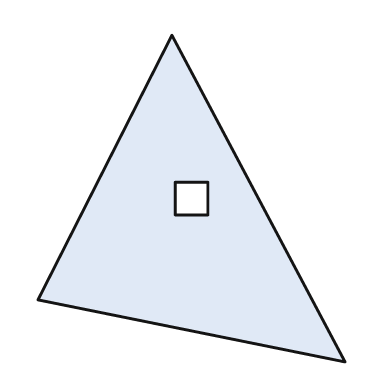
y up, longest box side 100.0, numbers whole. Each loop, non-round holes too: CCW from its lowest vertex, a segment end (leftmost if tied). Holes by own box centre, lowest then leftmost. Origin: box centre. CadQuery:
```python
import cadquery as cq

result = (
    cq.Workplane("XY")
    .moveTo(47.0, -50.0)
    .lineTo(-6.0, 50.0)
    .lineTo(-47.0, -31.0)
    .close()
    .moveTo(-5.0, -5.0)
    .lineTo(5.0, -5.0)
    .lineTo(5.0, 5.0)
    .lineTo(-5.0, 5.0)
    .close()
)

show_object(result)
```